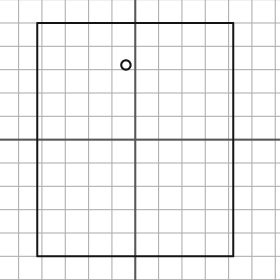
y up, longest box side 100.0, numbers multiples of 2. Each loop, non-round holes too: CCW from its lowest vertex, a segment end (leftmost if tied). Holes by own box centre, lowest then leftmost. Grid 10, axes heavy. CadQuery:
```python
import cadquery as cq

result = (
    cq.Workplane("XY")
    .moveTo(-42.0, -50.0)
    .lineTo(42.0, -50.0)
    .lineTo(42.0, 50.0)
    .lineTo(-42.0, 50.0)
    .close()
    .moveTo(-4.0, 32.0)
    .circle(2.0)
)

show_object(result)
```